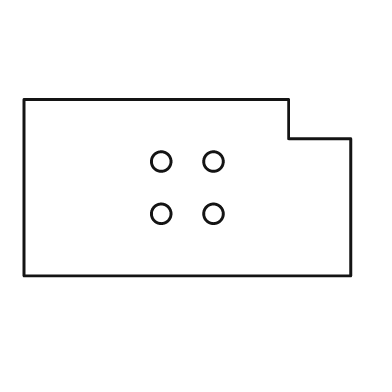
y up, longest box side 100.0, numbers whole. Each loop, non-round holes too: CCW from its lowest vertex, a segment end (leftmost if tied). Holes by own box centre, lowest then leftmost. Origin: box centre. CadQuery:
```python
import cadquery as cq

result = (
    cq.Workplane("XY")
    .moveTo(-50.0, -27.0)
    .lineTo(50.0, -27.0)
    .lineTo(50.0, 15.0)
    .lineTo(31.0, 15.0)
    .lineTo(31.0, 27.0)
    .lineTo(-50.0, 27.0)
    .close()
    .moveTo(-8.0, -8.0)
    .circle(3.0)
    .moveTo(8.0, -8.0)
    .circle(3.0)
    .moveTo(-8.0, 8.0)
    .circle(3.0)
    .moveTo(8.0, 8.0)
    .circle(3.0)
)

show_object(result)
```